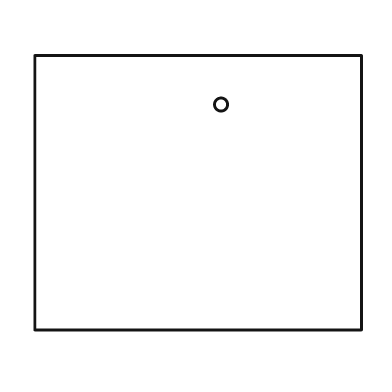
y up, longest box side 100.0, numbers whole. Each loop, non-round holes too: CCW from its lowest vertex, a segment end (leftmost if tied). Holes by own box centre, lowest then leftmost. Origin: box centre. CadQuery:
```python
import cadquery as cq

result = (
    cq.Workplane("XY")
    .moveTo(-50.0, -42.0)
    .lineTo(50.0, -42.0)
    .lineTo(50.0, 42.0)
    .lineTo(-50.0, 42.0)
    .close()
    .moveTo(7.0, 27.0)
    .circle(2.0)
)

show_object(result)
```